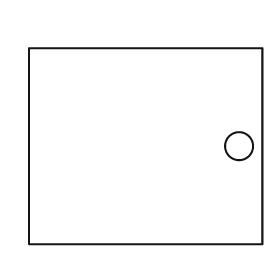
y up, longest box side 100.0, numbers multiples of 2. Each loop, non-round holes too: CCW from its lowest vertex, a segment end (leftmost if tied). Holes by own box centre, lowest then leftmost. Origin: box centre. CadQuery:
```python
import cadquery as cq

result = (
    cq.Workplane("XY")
    .moveTo(-50.0, -42.0)
    .lineTo(50.0, -42.0)
    .lineTo(50.0, 42.0)
    .lineTo(-50.0, 42.0)
    .close()
    .moveTo(40.0, 0.0)
    .circle(6.0)
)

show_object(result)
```